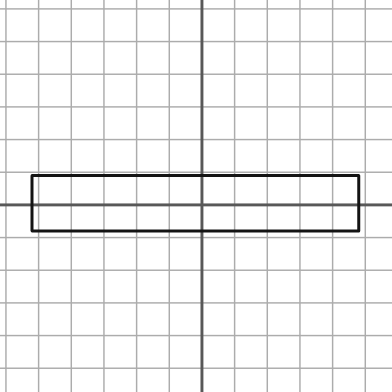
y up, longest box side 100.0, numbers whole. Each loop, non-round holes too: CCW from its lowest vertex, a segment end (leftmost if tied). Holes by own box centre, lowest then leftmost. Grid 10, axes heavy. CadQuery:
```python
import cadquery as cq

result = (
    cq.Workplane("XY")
    .moveTo(-52.0, -8.0)
    .lineTo(48.0, -8.0)
    .lineTo(48.0, 9.0)
    .lineTo(-52.0, 9.0)
    .close()
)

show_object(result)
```